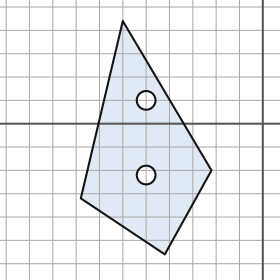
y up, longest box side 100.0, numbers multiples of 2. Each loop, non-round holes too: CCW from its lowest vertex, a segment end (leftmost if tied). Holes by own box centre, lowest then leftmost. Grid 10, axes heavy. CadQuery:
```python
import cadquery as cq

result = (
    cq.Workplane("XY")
    .moveTo(-42.0, -56.0)
    .lineTo(-22.0, -20.0)
    .lineTo(-60.0, 44.0)
    .lineTo(-78.0, -32.0)
    .close()
    .moveTo(-50.0, -22.0)
    .circle(4.0)
    .moveTo(-50.0, 10.0)
    .circle(4.0)
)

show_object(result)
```